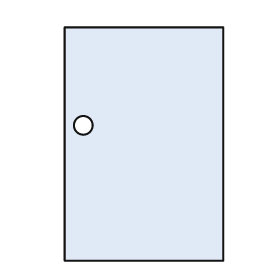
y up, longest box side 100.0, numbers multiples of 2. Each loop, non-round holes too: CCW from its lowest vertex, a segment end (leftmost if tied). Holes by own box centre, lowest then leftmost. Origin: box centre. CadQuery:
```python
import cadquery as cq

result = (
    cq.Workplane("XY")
    .moveTo(-34.0, -50.0)
    .lineTo(34.0, -50.0)
    .lineTo(34.0, 50.0)
    .lineTo(-34.0, 50.0)
    .close()
    .moveTo(-26.0, 8.0)
    .circle(4.0)
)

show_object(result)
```